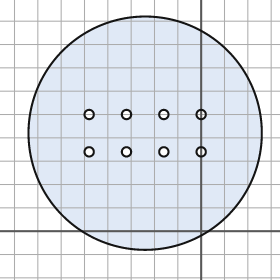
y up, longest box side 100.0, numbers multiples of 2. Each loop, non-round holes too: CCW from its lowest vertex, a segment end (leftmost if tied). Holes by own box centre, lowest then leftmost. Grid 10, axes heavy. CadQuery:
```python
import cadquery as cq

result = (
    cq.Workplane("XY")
    .moveTo(-24.0, 42.0)
    .circle(50.0)
    .moveTo(-48.0, 34.0)
    .circle(2.0)
    .moveTo(-32.0, 34.0)
    .circle(2.0)
    .moveTo(-16.0, 34.0)
    .circle(2.0)
    .moveTo(0.0, 34.0)
    .circle(2.0)
    .moveTo(-48.0, 50.0)
    .circle(2.0)
    .moveTo(-32.0, 50.0)
    .circle(2.0)
    .moveTo(-16.0, 50.0)
    .circle(2.0)
    .moveTo(0.0, 50.0)
    .circle(2.0)
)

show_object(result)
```